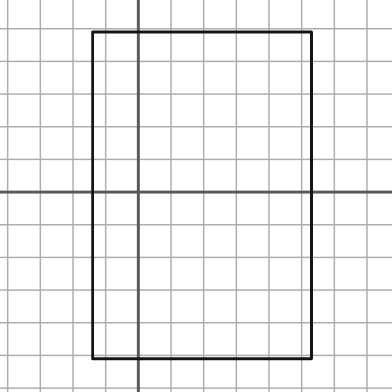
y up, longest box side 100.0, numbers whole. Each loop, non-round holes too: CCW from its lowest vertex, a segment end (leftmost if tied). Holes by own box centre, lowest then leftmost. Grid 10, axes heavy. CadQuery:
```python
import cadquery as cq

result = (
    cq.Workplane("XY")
    .moveTo(-14.0, -51.0)
    .lineTo(53.0, -51.0)
    .lineTo(53.0, 49.0)
    .lineTo(-14.0, 49.0)
    .close()
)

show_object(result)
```